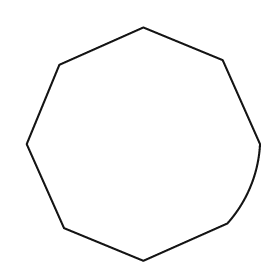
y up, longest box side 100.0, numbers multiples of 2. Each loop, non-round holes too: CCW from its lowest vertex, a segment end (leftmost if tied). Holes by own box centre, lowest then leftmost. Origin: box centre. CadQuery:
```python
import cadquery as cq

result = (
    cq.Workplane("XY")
    .moveTo(0.0, -50.0)
    .lineTo(36.0, -34.0)
    .threePointArc((46.0, -18.0), (50.0, 0.0))
    .lineTo(34.0, 36.0)
    .lineTo(0.0, 50.0)
    .lineTo(-36.0, 34.0)
    .lineTo(-50.0, 0.0)
    .lineTo(-34.0, -36.0)
    .close()
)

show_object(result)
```